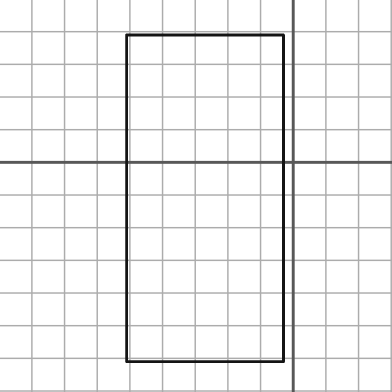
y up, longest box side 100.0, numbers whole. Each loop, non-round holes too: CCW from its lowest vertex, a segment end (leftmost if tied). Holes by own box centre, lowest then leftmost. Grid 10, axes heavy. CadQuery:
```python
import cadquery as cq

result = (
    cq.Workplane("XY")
    .moveTo(-51.0, -61.0)
    .lineTo(-3.0, -61.0)
    .lineTo(-3.0, 39.0)
    .lineTo(-51.0, 39.0)
    .close()
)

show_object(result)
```